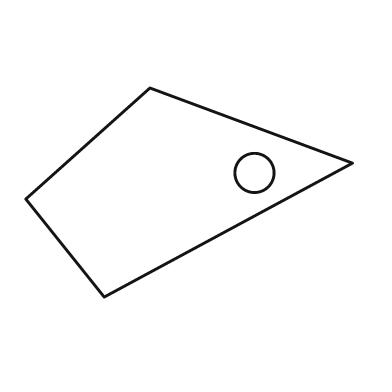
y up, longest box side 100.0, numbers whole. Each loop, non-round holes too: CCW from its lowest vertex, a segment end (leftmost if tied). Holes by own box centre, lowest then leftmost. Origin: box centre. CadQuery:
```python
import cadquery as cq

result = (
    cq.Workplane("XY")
    .moveTo(-26.0, -32.0)
    .lineTo(50.0, 9.0)
    .lineTo(-12.0, 32.0)
    .lineTo(-50.0, -2.0)
    .close()
    .moveTo(20.0, 6.0)
    .circle(6.0)
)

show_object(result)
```